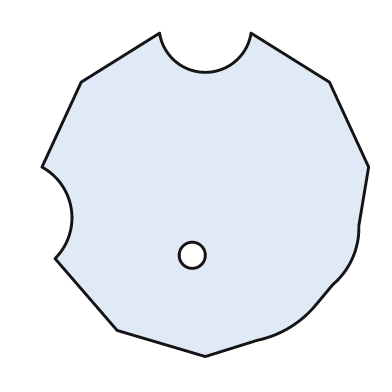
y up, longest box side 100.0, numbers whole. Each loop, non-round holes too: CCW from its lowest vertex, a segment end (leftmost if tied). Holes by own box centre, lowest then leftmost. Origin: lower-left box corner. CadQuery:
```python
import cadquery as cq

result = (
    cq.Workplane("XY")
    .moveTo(50.0, 0.0)
    .lineTo(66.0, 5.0)
    .threePointArc((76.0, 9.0), (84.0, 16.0))
    .lineTo(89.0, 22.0)
    .threePointArc((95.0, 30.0), (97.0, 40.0))
    .lineTo(100.0, 58.0)
    .lineTo(88.0, 84.0)
    .lineTo(64.0, 99.0)
    .threePointArc((50.0, 87.0), (36.0, 99.0))
    .lineTo(12.0, 84.0)
    .lineTo(0.0, 58.0)
    .threePointArc((9.0, 45.0), (4.0, 30.0))
    .lineTo(23.0, 8.0)
    .close()
    .moveTo(46.0, 31.0)
    .circle(4.0)
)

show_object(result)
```